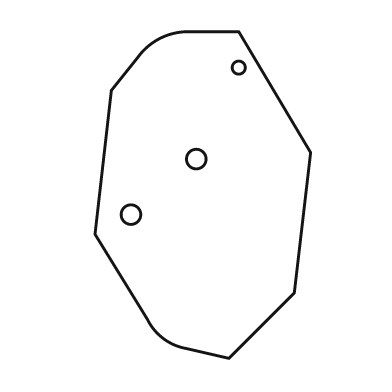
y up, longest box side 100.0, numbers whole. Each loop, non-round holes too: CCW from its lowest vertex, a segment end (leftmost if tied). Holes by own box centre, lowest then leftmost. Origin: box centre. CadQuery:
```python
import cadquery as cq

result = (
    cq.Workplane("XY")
    .moveTo(8.0, -50.0)
    .lineTo(28.0, -30.0)
    .lineTo(33.0, 13.0)
    .lineTo(11.0, 50.0)
    .lineTo(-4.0, 50.0)
    .threePointArc((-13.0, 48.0), (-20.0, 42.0))
    .lineTo(-28.0, 32.0)
    .lineTo(-33.0, -12.0)
    .lineTo(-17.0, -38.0)
    .threePointArc((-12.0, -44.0), (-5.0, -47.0))
    .close()
    .moveTo(-22.0, -6.0)
    .circle(3.0)
    .moveTo(-2.0, 11.0)
    .circle(3.0)
    .moveTo(11.0, 39.0)
    .circle(2.0)
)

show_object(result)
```